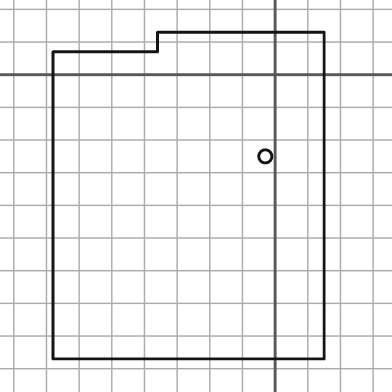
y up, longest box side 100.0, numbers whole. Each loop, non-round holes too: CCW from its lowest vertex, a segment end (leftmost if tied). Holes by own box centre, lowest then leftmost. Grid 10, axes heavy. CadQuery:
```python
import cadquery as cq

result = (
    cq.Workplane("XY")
    .moveTo(-68.0, -87.0)
    .lineTo(15.0, -87.0)
    .lineTo(15.0, 13.0)
    .lineTo(-36.0, 13.0)
    .lineTo(-36.0, 7.0)
    .lineTo(-68.0, 7.0)
    .close()
    .moveTo(-3.0, -25.0)
    .circle(2.0)
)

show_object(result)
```